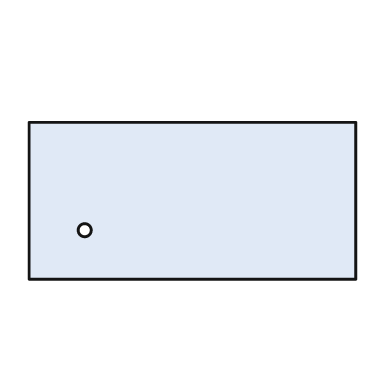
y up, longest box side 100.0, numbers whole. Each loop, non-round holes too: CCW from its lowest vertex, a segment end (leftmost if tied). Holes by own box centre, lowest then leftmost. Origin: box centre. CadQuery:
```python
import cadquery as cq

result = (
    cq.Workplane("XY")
    .moveTo(-50.0, -24.0)
    .lineTo(50.0, -24.0)
    .lineTo(50.0, 24.0)
    .lineTo(-50.0, 24.0)
    .close()
    .moveTo(-33.0, -9.0)
    .circle(2.0)
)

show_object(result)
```